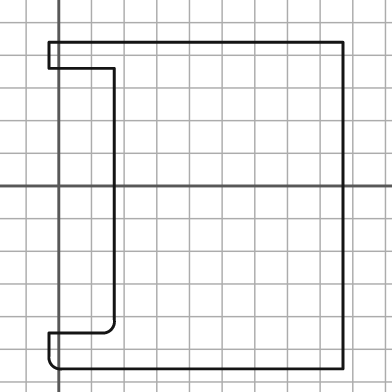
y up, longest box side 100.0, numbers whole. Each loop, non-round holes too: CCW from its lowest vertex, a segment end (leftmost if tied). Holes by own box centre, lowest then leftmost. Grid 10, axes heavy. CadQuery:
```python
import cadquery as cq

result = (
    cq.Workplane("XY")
    .moveTo(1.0, -56.0)
    .lineTo(87.0, -56.0)
    .lineTo(87.0, 44.0)
    .lineTo(-3.0, 44.0)
    .lineTo(-3.0, 36.0)
    .lineTo(17.0, 36.0)
    .lineTo(17.0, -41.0)
    .threePointArc((16.0, -44.0), (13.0, -45.0))
    .lineTo(-3.0, -45.0)
    .lineTo(-3.0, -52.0)
    .threePointArc((-2.0, -55.0), (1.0, -56.0))
    .close()
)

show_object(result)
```